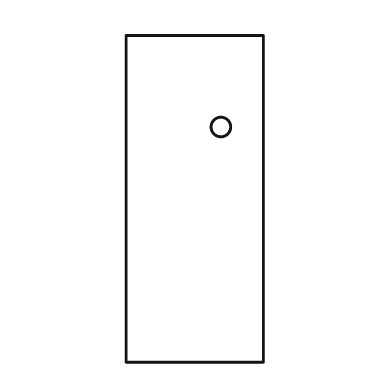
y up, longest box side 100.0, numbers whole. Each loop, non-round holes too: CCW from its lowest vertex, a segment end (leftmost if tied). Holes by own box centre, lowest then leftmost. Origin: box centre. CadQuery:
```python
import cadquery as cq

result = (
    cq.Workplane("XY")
    .moveTo(-21.0, -50.0)
    .lineTo(21.0, -50.0)
    .lineTo(21.0, 50.0)
    .lineTo(-21.0, 50.0)
    .close()
    .moveTo(8.0, 22.0)
    .circle(3.0)
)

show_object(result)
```